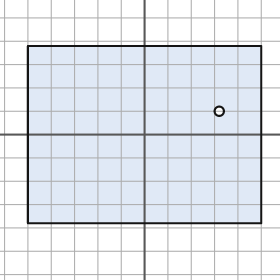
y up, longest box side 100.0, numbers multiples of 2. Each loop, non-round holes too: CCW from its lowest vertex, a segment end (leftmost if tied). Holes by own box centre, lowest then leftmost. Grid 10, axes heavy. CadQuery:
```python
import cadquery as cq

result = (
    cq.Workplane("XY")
    .moveTo(-50.0, -38.0)
    .lineTo(50.0, -38.0)
    .lineTo(50.0, 38.0)
    .lineTo(-50.0, 38.0)
    .close()
    .moveTo(32.0, 10.0)
    .circle(2.0)
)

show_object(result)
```